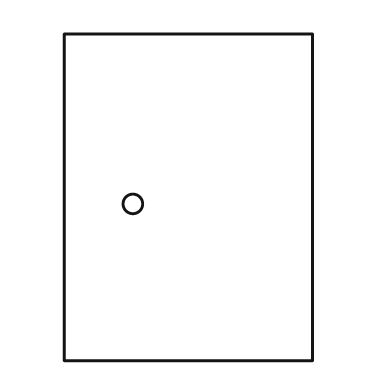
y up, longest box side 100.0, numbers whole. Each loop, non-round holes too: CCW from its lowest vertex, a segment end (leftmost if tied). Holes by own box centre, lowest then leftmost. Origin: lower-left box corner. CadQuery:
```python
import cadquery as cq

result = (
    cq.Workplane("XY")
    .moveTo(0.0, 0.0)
    .lineTo(76.0, 0.0)
    .lineTo(76.0, 100.0)
    .lineTo(0.0, 100.0)
    .close()
    .moveTo(21.0, 48.0)
    .circle(3.0)
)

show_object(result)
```